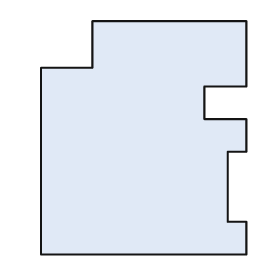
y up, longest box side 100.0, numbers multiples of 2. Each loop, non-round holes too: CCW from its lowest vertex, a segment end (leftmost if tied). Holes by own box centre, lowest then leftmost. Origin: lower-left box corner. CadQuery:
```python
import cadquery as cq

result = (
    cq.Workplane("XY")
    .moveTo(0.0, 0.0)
    .lineTo(88.0, 0.0)
    .lineTo(88.0, 14.0)
    .lineTo(80.0, 14.0)
    .lineTo(80.0, 44.0)
    .lineTo(88.0, 44.0)
    .lineTo(88.0, 58.0)
    .lineTo(70.0, 58.0)
    .lineTo(70.0, 72.0)
    .lineTo(88.0, 72.0)
    .lineTo(88.0, 100.0)
    .lineTo(22.0, 100.0)
    .lineTo(22.0, 80.0)
    .lineTo(0.0, 80.0)
    .close()
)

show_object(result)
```